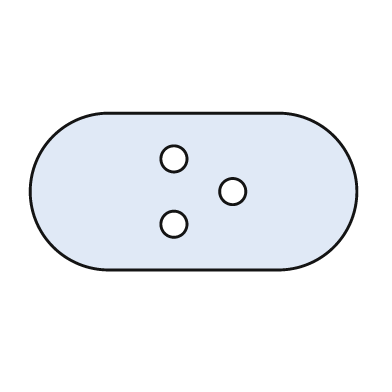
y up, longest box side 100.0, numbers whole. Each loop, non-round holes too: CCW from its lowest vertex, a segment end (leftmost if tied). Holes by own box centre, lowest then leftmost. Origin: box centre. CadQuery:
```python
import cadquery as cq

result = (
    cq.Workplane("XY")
    .moveTo(-26.0, -24.0)
    .lineTo(26.0, -24.0)
    .threePointArc((50.0, 0.0), (26.0, 24.0))
    .lineTo(-26.0, 24.0)
    .threePointArc((-50.0, 0.0), (-26.0, -24.0))
    .close()
    .moveTo(-6.0, -10.0)
    .circle(4.0)
    .moveTo(12.0, 0.0)
    .circle(4.0)
    .moveTo(-6.0, 10.0)
    .circle(4.0)
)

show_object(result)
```